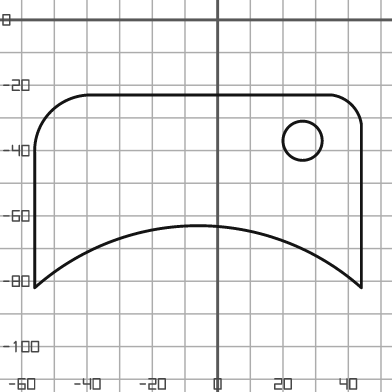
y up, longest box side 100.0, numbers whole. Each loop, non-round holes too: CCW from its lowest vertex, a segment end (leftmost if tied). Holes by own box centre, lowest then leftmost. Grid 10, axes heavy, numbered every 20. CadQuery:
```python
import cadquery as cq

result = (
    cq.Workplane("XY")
    .moveTo(-56.0, -82.0)
    .threePointArc((-6.0, -63.0), (44.0, -82.0))
    .lineTo(44.0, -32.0)
    .threePointArc((41.0, -26.0), (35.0, -23.0))
    .lineTo(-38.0, -23.0)
    .threePointArc((-51.0, -28.0), (-56.0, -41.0))
    .close()
    .moveTo(26.0, -37.0)
    .circle(6.0)
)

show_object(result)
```